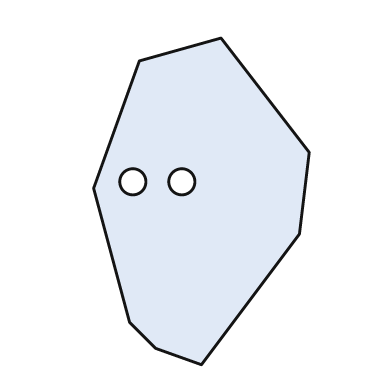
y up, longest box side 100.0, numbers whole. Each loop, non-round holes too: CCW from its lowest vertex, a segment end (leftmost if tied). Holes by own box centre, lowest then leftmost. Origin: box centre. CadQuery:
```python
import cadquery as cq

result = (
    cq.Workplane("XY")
    .moveTo(0.0, -50.0)
    .lineTo(30.0, -10.0)
    .lineTo(33.0, 15.0)
    .lineTo(6.0, 50.0)
    .lineTo(-19.0, 43.0)
    .lineTo(-33.0, 4.0)
    .lineTo(-22.0, -37.0)
    .lineTo(-14.0, -45.0)
    .close()
    .moveTo(-21.0, 6.0)
    .circle(4.0)
    .moveTo(-6.0, 6.0)
    .circle(4.0)
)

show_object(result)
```